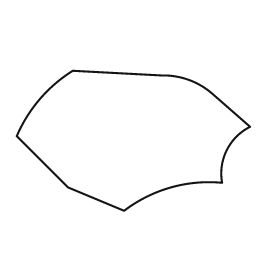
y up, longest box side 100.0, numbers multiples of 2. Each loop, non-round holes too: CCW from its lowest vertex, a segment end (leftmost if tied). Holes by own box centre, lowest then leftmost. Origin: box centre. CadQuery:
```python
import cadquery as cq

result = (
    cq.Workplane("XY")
    .moveTo(-4.0, -30.0)
    .threePointArc((16.0, -20.0), (38.0, -18.0))
    .threePointArc((40.0, -4.0), (50.0, 6.0))
    .lineTo(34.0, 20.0)
    .threePointArc((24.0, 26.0), (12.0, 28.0))
    .lineTo(-26.0, 30.0)
    .threePointArc((-40.0, 18.0), (-50.0, 2.0))
    .lineTo(-28.0, -20.0)
    .close()
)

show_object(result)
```